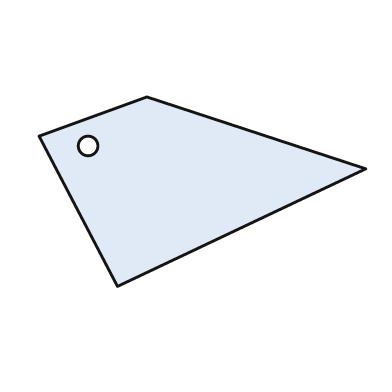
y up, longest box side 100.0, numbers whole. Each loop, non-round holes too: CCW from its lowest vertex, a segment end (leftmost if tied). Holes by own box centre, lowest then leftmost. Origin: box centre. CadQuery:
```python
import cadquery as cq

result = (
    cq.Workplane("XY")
    .moveTo(-26.0, -29.0)
    .lineTo(50.0, 7.0)
    .lineTo(-17.0, 29.0)
    .lineTo(-50.0, 17.0)
    .close()
    .moveTo(-35.0, 14.0)
    .circle(3.0)
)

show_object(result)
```